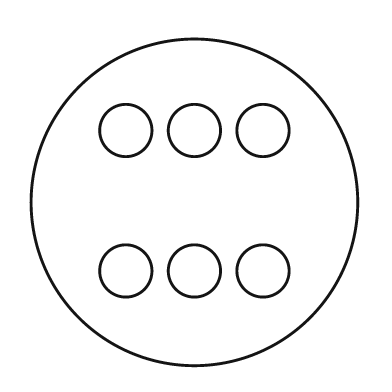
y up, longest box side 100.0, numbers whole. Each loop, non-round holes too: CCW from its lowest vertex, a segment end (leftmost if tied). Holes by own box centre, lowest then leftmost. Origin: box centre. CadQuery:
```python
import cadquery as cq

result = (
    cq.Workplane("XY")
    .moveTo(0.0, 0.0)
    .circle(50.0)
    .moveTo(-21.0, -21.0)
    .circle(8.0)
    .moveTo(0.0, -21.0)
    .circle(8.0)
    .moveTo(21.0, -21.0)
    .circle(8.0)
    .moveTo(-21.0, 22.0)
    .circle(8.0)
    .moveTo(0.0, 22.0)
    .circle(8.0)
    .moveTo(21.0, 22.0)
    .circle(8.0)
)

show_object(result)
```